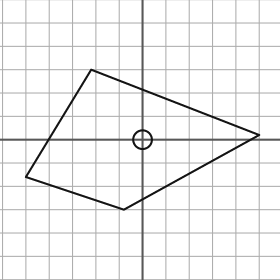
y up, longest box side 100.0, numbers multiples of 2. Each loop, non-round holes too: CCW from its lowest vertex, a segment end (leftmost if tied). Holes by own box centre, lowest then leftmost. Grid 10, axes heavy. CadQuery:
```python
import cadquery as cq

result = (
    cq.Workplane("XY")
    .moveTo(-8.0, -30.0)
    .lineTo(50.0, 2.0)
    .lineTo(-22.0, 30.0)
    .lineTo(-50.0, -16.0)
    .close()
    .moveTo(0.0, 0.0)
    .circle(4.0)
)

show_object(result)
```